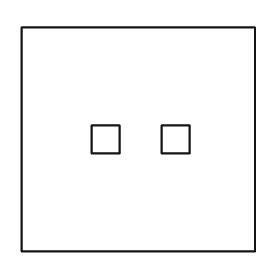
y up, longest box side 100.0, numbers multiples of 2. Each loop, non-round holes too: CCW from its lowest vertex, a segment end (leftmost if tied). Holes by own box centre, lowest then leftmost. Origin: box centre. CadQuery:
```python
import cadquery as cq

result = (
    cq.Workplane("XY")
    .moveTo(-50.0, -48.0)
    .lineTo(50.0, -48.0)
    .lineTo(50.0, 48.0)
    .lineTo(-50.0, 48.0)
    .close()
    .moveTo(-20.0, -6.0)
    .lineTo(-8.0, -6.0)
    .lineTo(-8.0, 6.0)
    .lineTo(-20.0, 6.0)
    .close()
    .moveTo(10.0, -6.0)
    .lineTo(22.0, -6.0)
    .lineTo(22.0, 6.0)
    .lineTo(10.0, 6.0)
    .close()
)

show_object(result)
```